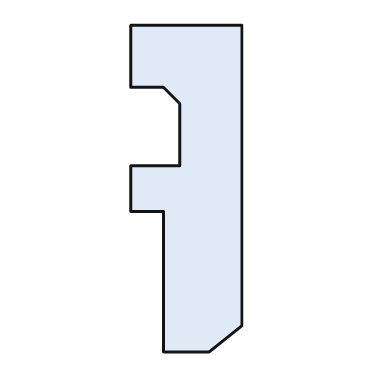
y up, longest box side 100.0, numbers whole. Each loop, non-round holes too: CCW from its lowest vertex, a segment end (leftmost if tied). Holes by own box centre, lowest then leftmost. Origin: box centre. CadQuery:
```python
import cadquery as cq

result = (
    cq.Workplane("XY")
    .moveTo(-7.0, -50.0)
    .lineTo(7.0, -50.0)
    .lineTo(17.0, -42.0)
    .lineTo(17.0, 50.0)
    .lineTo(-17.0, 50.0)
    .lineTo(-17.0, 31.0)
    .lineTo(-7.0, 31.0)
    .lineTo(-2.0, 26.0)
    .lineTo(-2.0, 7.0)
    .lineTo(-17.0, 7.0)
    .lineTo(-17.0, -7.0)
    .lineTo(-7.0, -7.0)
    .close()
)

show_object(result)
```